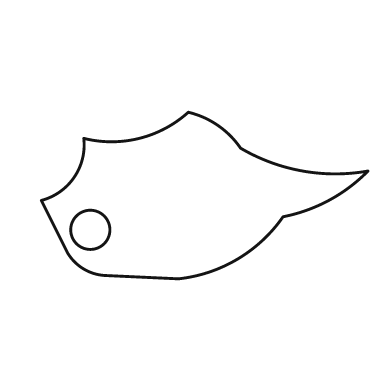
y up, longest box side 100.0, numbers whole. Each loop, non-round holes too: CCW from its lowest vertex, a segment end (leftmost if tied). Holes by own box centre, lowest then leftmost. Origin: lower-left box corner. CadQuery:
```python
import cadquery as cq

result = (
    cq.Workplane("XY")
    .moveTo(42.0, 0.0)
    .threePointArc((60.0, 6.0), (74.0, 19.0))
    .threePointArc((88.0, 24.0), (100.0, 33.0))
    .threePointArc((80.0, 33.0), (61.0, 40.0))
    .threePointArc((54.0, 47.0), (45.0, 51.0))
    .threePointArc((30.0, 43.0), (13.0, 43.0))
    .threePointArc((10.0, 31.0), (0.0, 24.0))
    .lineTo(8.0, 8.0)
    .threePointArc((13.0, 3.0), (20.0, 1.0))
    .close()
    .moveTo(15.0, 15.0)
    .circle(6.0)
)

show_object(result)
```